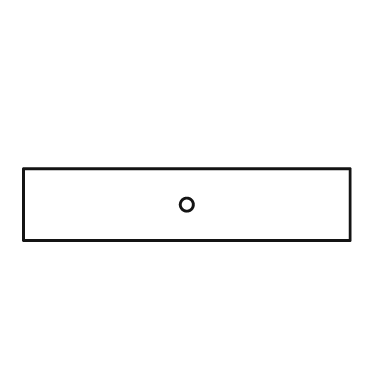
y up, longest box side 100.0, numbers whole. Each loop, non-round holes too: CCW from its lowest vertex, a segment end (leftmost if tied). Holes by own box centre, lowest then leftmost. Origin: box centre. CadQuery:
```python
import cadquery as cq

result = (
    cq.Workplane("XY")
    .moveTo(-50.0, -11.0)
    .lineTo(50.0, -11.0)
    .lineTo(50.0, 11.0)
    .lineTo(-50.0, 11.0)
    .close()
    .moveTo(0.0, 0.0)
    .circle(2.0)
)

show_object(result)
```